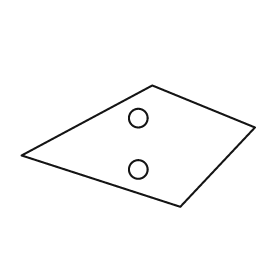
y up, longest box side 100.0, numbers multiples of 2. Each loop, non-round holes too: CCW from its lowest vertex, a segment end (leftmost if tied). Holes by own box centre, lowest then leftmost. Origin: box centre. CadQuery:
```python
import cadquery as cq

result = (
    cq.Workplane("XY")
    .moveTo(18.0, -26.0)
    .lineTo(50.0, 8.0)
    .lineTo(6.0, 26.0)
    .lineTo(-50.0, -4.0)
    .close()
    .moveTo(0.0, -10.0)
    .circle(4.0)
    .moveTo(0.0, 12.0)
    .circle(4.0)
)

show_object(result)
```